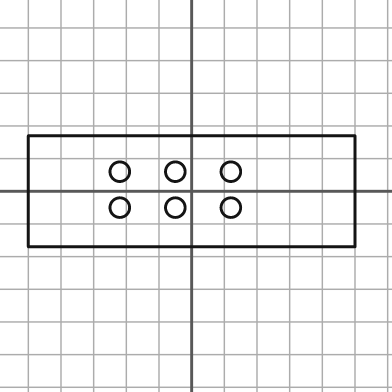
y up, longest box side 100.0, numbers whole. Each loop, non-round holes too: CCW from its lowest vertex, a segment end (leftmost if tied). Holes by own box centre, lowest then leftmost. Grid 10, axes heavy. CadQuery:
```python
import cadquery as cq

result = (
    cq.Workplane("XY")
    .moveTo(-50.0, -17.0)
    .lineTo(50.0, -17.0)
    .lineTo(50.0, 17.0)
    .lineTo(-50.0, 17.0)
    .close()
    .moveTo(-22.0, -5.0)
    .circle(3.0)
    .moveTo(-5.0, -5.0)
    .circle(3.0)
    .moveTo(12.0, -5.0)
    .circle(3.0)
    .moveTo(-22.0, 6.0)
    .circle(3.0)
    .moveTo(-5.0, 6.0)
    .circle(3.0)
    .moveTo(12.0, 6.0)
    .circle(3.0)
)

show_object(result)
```